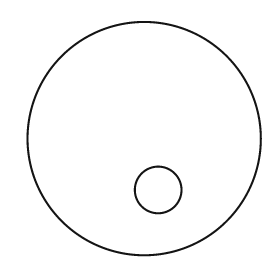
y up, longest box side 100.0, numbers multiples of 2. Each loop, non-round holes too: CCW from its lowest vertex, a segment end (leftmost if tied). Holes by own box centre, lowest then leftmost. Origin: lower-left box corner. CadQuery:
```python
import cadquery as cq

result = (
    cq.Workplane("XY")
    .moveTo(50.0, 50.0)
    .circle(50.0)
    .moveTo(56.0, 28.0)
    .circle(10.0)
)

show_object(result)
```